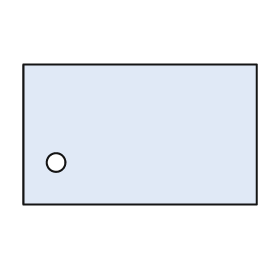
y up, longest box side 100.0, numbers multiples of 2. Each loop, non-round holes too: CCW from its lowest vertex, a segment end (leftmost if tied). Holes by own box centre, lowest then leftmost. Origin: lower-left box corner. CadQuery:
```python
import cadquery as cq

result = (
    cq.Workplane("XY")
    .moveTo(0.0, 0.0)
    .lineTo(100.0, 0.0)
    .lineTo(100.0, 60.0)
    .lineTo(0.0, 60.0)
    .close()
    .moveTo(14.0, 18.0)
    .circle(4.0)
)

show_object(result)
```